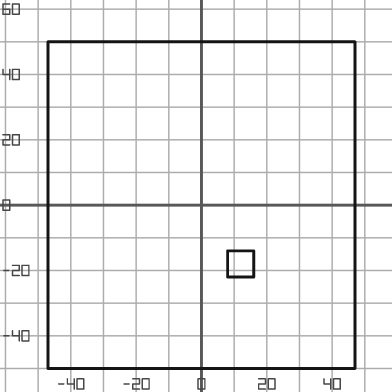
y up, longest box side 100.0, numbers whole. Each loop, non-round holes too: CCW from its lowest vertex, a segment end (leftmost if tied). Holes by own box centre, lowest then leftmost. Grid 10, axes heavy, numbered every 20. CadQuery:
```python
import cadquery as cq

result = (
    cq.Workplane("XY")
    .moveTo(-47.0, -50.0)
    .lineTo(47.0, -50.0)
    .lineTo(47.0, 50.0)
    .lineTo(-47.0, 50.0)
    .close()
    .moveTo(8.0, -22.0)
    .lineTo(16.0, -22.0)
    .lineTo(16.0, -14.0)
    .lineTo(8.0, -14.0)
    .close()
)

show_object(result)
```